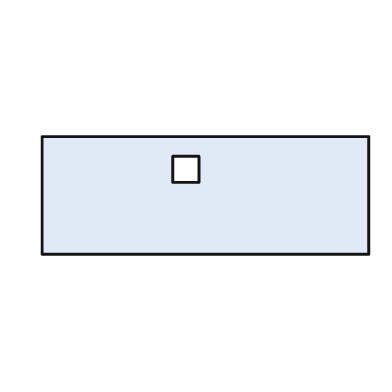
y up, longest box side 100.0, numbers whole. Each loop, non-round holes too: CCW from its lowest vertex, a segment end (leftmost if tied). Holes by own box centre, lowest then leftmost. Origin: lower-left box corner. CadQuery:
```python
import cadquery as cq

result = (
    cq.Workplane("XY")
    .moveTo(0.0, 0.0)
    .lineTo(100.0, 0.0)
    .lineTo(100.0, 36.0)
    .lineTo(0.0, 36.0)
    .close()
    .moveTo(40.0, 22.0)
    .lineTo(48.0, 22.0)
    .lineTo(48.0, 30.0)
    .lineTo(40.0, 30.0)
    .close()
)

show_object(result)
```